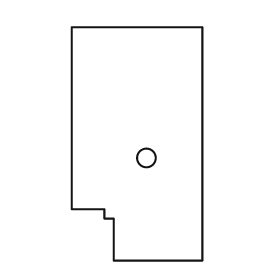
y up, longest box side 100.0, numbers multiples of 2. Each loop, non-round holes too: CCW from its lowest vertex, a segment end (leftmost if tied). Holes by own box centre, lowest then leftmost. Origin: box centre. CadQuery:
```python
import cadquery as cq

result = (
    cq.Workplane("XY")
    .moveTo(-10.0, -50.0)
    .lineTo(28.0, -50.0)
    .lineTo(28.0, 50.0)
    .lineTo(-28.0, 50.0)
    .lineTo(-28.0, -28.0)
    .lineTo(-14.0, -28.0)
    .lineTo(-14.0, -32.0)
    .lineTo(-10.0, -32.0)
    .close()
    .moveTo(4.0, -6.0)
    .circle(4.0)
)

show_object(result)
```